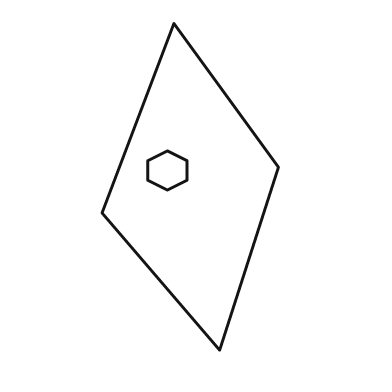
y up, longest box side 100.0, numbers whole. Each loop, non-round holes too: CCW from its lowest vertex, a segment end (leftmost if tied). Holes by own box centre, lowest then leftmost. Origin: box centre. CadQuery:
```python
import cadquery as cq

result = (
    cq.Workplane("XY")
    .moveTo(9.0, -50.0)
    .lineTo(27.0, 6.0)
    .lineTo(-5.0, 50.0)
    .lineTo(-27.0, -8.0)
    .close()
    .moveTo(-7.0, -1.0)
    .lineTo(-1.0, 2.0)
    .lineTo(-1.0, 8.0)
    .lineTo(-7.0, 11.0)
    .lineTo(-13.0, 8.0)
    .lineTo(-13.0, 2.0)
    .close()
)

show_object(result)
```